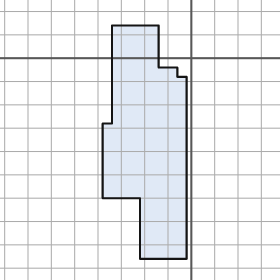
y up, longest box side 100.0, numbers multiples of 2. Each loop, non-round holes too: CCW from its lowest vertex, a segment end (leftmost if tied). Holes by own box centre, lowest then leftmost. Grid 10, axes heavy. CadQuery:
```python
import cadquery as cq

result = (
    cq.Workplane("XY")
    .moveTo(-22.0, -86.0)
    .lineTo(-2.0, -86.0)
    .lineTo(-2.0, -8.0)
    .lineTo(-6.0, -8.0)
    .lineTo(-6.0, -4.0)
    .lineTo(-14.0, -4.0)
    .lineTo(-14.0, 14.0)
    .lineTo(-34.0, 14.0)
    .lineTo(-34.0, -28.0)
    .lineTo(-38.0, -28.0)
    .lineTo(-38.0, -60.0)
    .lineTo(-22.0, -60.0)
    .close()
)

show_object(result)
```